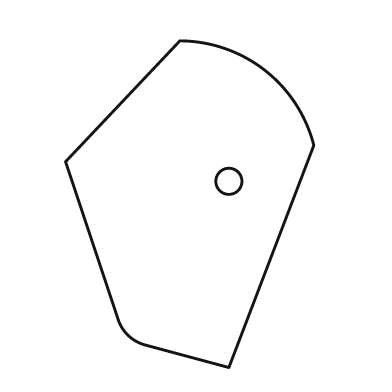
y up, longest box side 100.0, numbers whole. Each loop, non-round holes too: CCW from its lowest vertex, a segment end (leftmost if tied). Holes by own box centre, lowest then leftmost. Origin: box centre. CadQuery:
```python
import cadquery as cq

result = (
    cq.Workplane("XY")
    .moveTo(12.0, -50.0)
    .lineTo(38.0, 18.0)
    .threePointArc((23.0, 41.0), (-3.0, 50.0))
    .lineTo(-38.0, 13.0)
    .lineTo(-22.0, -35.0)
    .threePointArc((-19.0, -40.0), (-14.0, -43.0))
    .close()
    .moveTo(12.0, 7.0)
    .circle(4.0)
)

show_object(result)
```